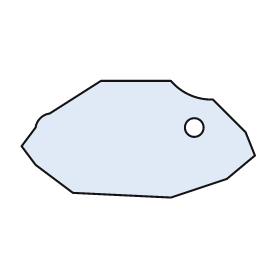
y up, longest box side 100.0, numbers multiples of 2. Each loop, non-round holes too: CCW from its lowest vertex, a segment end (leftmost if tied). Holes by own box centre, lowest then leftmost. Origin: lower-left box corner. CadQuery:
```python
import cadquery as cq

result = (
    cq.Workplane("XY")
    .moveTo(64.0, 0.0)
    .lineTo(88.0, 8.0)
    .lineTo(100.0, 18.0)
    .lineTo(96.0, 28.0)
    .lineTo(82.0, 42.0)
    .threePointArc((72.0, 44.0), (64.0, 50.0))
    .lineTo(34.0, 50.0)
    .lineTo(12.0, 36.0)
    .threePointArc((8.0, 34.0), (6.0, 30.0))
    .lineTo(0.0, 22.0)
    .lineTo(6.0, 14.0)
    .lineTo(22.0, 2.0)
    .close()
    .moveTo(74.0, 30.0)
    .circle(4.0)
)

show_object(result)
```